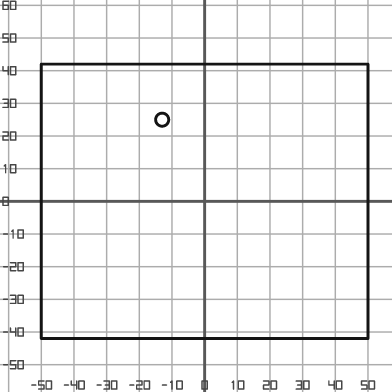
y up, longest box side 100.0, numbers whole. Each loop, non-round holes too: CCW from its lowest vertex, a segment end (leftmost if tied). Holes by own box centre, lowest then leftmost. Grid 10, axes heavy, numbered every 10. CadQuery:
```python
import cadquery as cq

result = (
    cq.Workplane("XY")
    .moveTo(-50.0, -42.0)
    .lineTo(50.0, -42.0)
    .lineTo(50.0, 42.0)
    .lineTo(-50.0, 42.0)
    .close()
    .moveTo(-13.0, 25.0)
    .circle(2.0)
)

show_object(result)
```